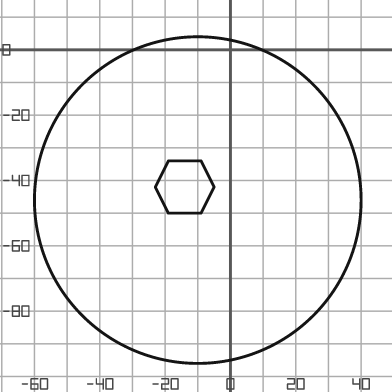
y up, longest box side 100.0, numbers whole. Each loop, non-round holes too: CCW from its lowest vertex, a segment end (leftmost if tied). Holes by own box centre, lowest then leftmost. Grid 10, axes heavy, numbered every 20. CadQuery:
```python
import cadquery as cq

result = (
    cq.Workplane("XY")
    .moveTo(-10.0, -46.0)
    .circle(50.0)
    .moveTo(-19.0, -50.0)
    .lineTo(-9.0, -50.0)
    .lineTo(-5.0, -42.0)
    .lineTo(-9.0, -34.0)
    .lineTo(-19.0, -34.0)
    .lineTo(-23.0, -42.0)
    .close()
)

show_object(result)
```